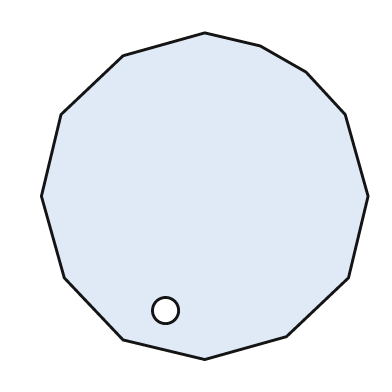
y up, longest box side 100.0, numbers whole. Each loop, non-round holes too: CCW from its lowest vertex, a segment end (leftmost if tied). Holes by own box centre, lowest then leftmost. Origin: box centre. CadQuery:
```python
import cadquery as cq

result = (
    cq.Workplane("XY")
    .moveTo(0.0, -50.0)
    .lineTo(25.0, -43.0)
    .lineTo(44.0, -25.0)
    .lineTo(50.0, 0.0)
    .lineTo(43.0, 25.0)
    .lineTo(31.0, 38.0)
    .lineTo(17.0, 46.0)
    .lineTo(0.0, 50.0)
    .lineTo(-25.0, 43.0)
    .lineTo(-44.0, 25.0)
    .lineTo(-50.0, 0.0)
    .lineTo(-43.0, -25.0)
    .lineTo(-25.0, -44.0)
    .close()
    .moveTo(-12.0, -35.0)
    .circle(4.0)
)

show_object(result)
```